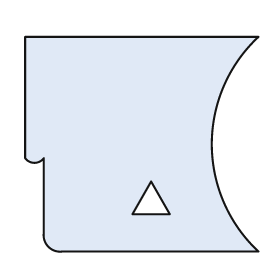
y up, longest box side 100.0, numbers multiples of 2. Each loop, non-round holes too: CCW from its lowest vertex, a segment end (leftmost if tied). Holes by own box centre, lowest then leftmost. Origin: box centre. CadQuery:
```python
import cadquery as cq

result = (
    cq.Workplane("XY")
    .moveTo(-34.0, -46.0)
    .lineTo(50.0, -46.0)
    .threePointArc((30.0, 0.0), (50.0, 46.0))
    .lineTo(-50.0, 46.0)
    .lineTo(-50.0, -6.0)
    .threePointArc((-46.0, -8.0), (-42.0, -6.0))
    .lineTo(-42.0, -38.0)
    .threePointArc((-40.0, -44.0), (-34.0, -46.0))
    .close()
    .moveTo(-4.0, -30.0)
    .lineTo(12.0, -30.0)
    .lineTo(4.0, -16.0)
    .close()
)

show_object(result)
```